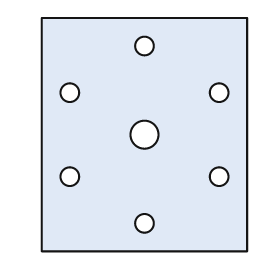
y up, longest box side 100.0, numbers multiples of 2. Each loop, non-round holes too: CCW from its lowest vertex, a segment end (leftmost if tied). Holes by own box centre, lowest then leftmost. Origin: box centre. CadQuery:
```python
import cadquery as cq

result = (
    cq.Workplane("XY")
    .moveTo(-44.0, -50.0)
    .lineTo(44.0, -50.0)
    .lineTo(44.0, 50.0)
    .lineTo(-44.0, 50.0)
    .close()
    .moveTo(0.0, -38.0)
    .circle(4.0)
    .moveTo(-32.0, -18.0)
    .circle(4.0)
    .moveTo(32.0, -18.0)
    .circle(4.0)
    .moveTo(0.0, 0.0)
    .circle(6.0)
    .moveTo(-32.0, 18.0)
    .circle(4.0)
    .moveTo(32.0, 18.0)
    .circle(4.0)
    .moveTo(0.0, 38.0)
    .circle(4.0)
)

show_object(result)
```